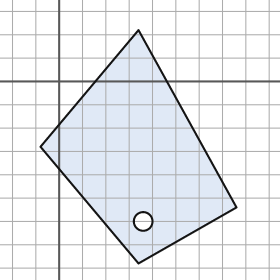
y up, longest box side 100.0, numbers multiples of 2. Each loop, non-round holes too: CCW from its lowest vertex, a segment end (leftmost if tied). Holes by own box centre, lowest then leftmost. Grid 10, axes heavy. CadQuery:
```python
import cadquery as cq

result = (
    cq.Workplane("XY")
    .moveTo(34.0, -78.0)
    .lineTo(76.0, -54.0)
    .lineTo(34.0, 22.0)
    .lineTo(-8.0, -28.0)
    .close()
    .moveTo(36.0, -60.0)
    .circle(4.0)
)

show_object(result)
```